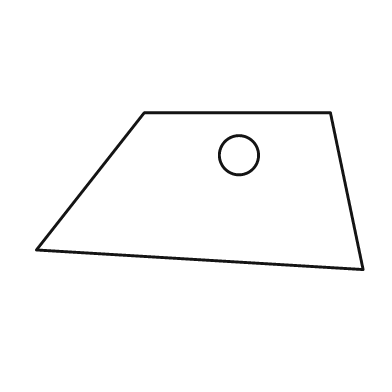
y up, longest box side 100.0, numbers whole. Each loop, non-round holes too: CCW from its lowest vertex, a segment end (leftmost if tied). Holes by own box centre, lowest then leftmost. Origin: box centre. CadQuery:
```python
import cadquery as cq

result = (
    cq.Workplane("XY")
    .moveTo(50.0, -24.0)
    .lineTo(40.0, 24.0)
    .lineTo(-17.0, 24.0)
    .lineTo(-50.0, -18.0)
    .close()
    .moveTo(12.0, 11.0)
    .circle(6.0)
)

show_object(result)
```